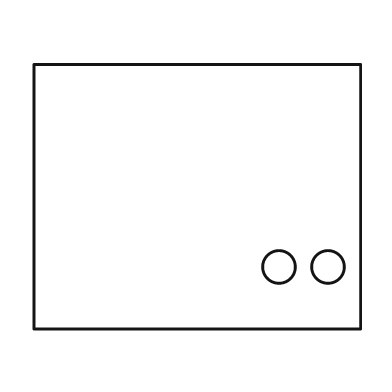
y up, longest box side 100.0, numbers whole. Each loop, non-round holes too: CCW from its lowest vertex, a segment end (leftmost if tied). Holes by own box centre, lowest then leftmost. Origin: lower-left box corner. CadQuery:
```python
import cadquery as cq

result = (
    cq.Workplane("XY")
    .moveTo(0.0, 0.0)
    .lineTo(100.0, 0.0)
    .lineTo(100.0, 81.0)
    .lineTo(0.0, 81.0)
    .close()
    .moveTo(75.0, 19.0)
    .circle(5.0)
    .moveTo(90.0, 19.0)
    .circle(5.0)
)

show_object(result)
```